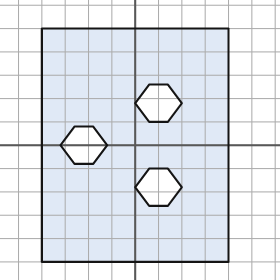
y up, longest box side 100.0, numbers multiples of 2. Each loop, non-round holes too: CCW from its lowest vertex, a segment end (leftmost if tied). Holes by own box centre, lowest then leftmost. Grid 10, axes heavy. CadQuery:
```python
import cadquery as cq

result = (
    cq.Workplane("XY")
    .moveTo(-40.0, -50.0)
    .lineTo(40.0, -50.0)
    .lineTo(40.0, 50.0)
    .lineTo(-40.0, 50.0)
    .close()
    .moveTo(6.0, -26.0)
    .lineTo(14.0, -26.0)
    .lineTo(20.0, -18.0)
    .lineTo(14.0, -10.0)
    .lineTo(6.0, -10.0)
    .lineTo(0.0, -18.0)
    .close()
    .moveTo(-26.0, -8.0)
    .lineTo(-18.0, -8.0)
    .lineTo(-12.0, 0.0)
    .lineTo(-18.0, 8.0)
    .lineTo(-26.0, 8.0)
    .lineTo(-32.0, 0.0)
    .close()
    .moveTo(6.0, 10.0)
    .lineTo(14.0, 10.0)
    .lineTo(20.0, 18.0)
    .lineTo(14.0, 26.0)
    .lineTo(6.0, 26.0)
    .lineTo(0.0, 18.0)
    .close()
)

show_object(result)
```